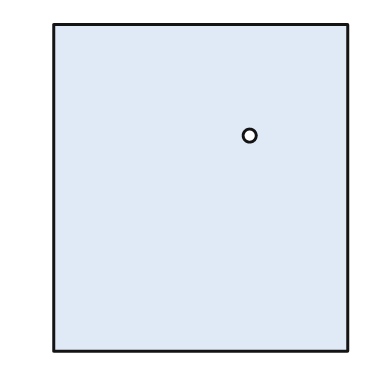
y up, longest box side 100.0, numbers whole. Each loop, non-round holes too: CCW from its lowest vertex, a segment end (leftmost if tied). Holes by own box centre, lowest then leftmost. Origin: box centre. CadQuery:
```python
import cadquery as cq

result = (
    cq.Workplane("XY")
    .moveTo(-45.0, -50.0)
    .lineTo(45.0, -50.0)
    .lineTo(45.0, 50.0)
    .lineTo(-45.0, 50.0)
    .close()
    .moveTo(15.0, 16.0)
    .circle(2.0)
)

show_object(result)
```